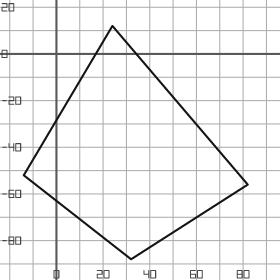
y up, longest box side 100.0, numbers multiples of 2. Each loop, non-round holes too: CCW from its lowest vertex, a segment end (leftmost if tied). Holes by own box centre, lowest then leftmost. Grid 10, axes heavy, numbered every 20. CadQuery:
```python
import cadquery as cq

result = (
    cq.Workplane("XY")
    .moveTo(32.0, -88.0)
    .lineTo(82.0, -56.0)
    .lineTo(24.0, 12.0)
    .lineTo(-14.0, -52.0)
    .close()
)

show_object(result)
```